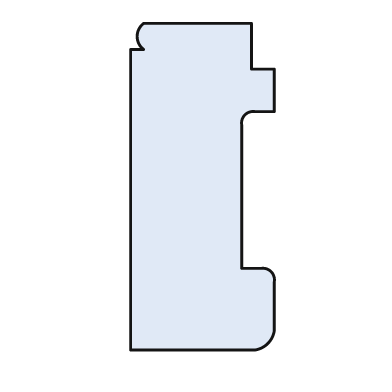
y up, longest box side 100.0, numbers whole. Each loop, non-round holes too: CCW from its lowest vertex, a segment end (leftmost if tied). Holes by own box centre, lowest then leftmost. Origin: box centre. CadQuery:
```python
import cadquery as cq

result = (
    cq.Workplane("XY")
    .moveTo(-22.0, -50.0)
    .lineTo(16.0, -50.0)
    .threePointArc((20.0, -48.0), (22.0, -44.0))
    .lineTo(22.0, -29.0)
    .threePointArc((21.0, -26.0), (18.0, -25.0))
    .lineTo(12.0, -25.0)
    .lineTo(12.0, 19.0)
    .threePointArc((13.0, 22.0), (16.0, 23.0))
    .lineTo(22.0, 23.0)
    .lineTo(22.0, 36.0)
    .lineTo(15.0, 36.0)
    .lineTo(15.0, 50.0)
    .lineTo(-18.0, 50.0)
    .threePointArc((-20.0, 46.0), (-18.0, 42.0))
    .lineTo(-22.0, 42.0)
    .close()
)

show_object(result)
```